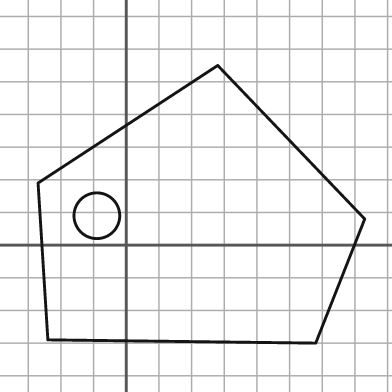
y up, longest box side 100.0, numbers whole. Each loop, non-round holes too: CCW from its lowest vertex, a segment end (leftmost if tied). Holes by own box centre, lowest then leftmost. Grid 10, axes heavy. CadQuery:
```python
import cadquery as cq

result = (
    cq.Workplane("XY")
    .moveTo(58.0, -30.0)
    .lineTo(73.0, 8.0)
    .lineTo(28.0, 55.0)
    .lineTo(-27.0, 19.0)
    .lineTo(-24.0, -29.0)
    .close()
    .moveTo(-9.0, 9.0)
    .circle(7.0)
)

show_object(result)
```